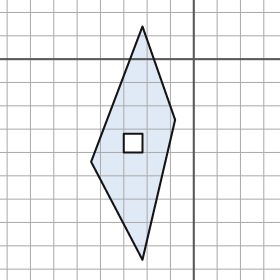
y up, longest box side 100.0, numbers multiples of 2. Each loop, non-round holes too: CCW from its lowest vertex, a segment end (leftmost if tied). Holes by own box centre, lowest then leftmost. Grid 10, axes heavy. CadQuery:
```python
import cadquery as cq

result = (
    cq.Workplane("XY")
    .moveTo(-22.0, -86.0)
    .lineTo(-8.0, -26.0)
    .lineTo(-22.0, 14.0)
    .lineTo(-44.0, -44.0)
    .close()
    .moveTo(-30.0, -40.0)
    .lineTo(-22.0, -40.0)
    .lineTo(-22.0, -32.0)
    .lineTo(-30.0, -32.0)
    .close()
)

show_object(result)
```